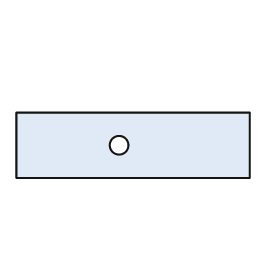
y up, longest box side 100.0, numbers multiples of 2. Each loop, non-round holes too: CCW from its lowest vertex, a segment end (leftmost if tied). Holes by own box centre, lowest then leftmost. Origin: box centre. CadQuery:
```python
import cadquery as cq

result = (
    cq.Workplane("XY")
    .moveTo(-50.0, -14.0)
    .lineTo(50.0, -14.0)
    .lineTo(50.0, 14.0)
    .lineTo(-50.0, 14.0)
    .close()
    .moveTo(-6.0, 0.0)
    .circle(4.0)
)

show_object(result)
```